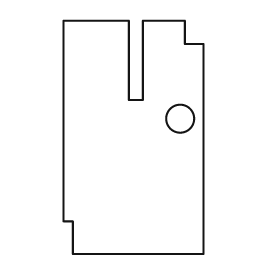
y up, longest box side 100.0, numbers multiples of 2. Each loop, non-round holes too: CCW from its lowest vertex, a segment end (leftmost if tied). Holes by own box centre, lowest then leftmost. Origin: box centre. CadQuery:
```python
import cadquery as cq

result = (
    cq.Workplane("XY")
    .moveTo(-26.0, -50.0)
    .lineTo(30.0, -50.0)
    .lineTo(30.0, 40.0)
    .lineTo(22.0, 40.0)
    .lineTo(22.0, 50.0)
    .lineTo(4.0, 50.0)
    .lineTo(4.0, 16.0)
    .lineTo(-2.0, 16.0)
    .lineTo(-2.0, 50.0)
    .lineTo(-30.0, 50.0)
    .lineTo(-30.0, -36.0)
    .lineTo(-26.0, -36.0)
    .close()
    .moveTo(20.0, 8.0)
    .circle(6.0)
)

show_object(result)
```